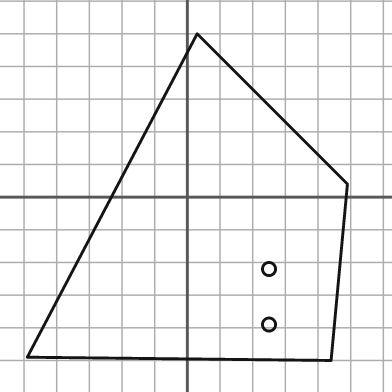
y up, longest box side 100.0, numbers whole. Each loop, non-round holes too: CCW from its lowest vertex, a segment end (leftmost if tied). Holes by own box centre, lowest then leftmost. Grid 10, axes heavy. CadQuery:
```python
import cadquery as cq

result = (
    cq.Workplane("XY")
    .moveTo(44.0, -50.0)
    .lineTo(49.0, 4.0)
    .lineTo(3.0, 50.0)
    .lineTo(-49.0, -49.0)
    .close()
    .moveTo(25.0, -39.0)
    .circle(2.0)
    .moveTo(25.0, -22.0)
    .circle(2.0)
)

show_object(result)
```